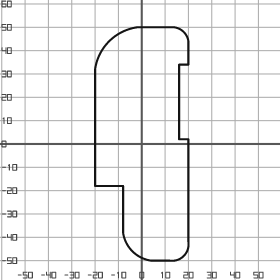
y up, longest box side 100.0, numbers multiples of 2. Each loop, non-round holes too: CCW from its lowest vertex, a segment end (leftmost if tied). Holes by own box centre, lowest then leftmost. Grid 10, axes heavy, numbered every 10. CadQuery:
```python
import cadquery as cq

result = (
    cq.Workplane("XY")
    .moveTo(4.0, -50.0)
    .lineTo(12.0, -50.0)
    .threePointArc((18.0, -48.0), (20.0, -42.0))
    .lineTo(20.0, 2.0)
    .lineTo(16.0, 2.0)
    .lineTo(16.0, 34.0)
    .lineTo(20.0, 34.0)
    .lineTo(20.0, 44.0)
    .threePointArc((18.0, 48.0), (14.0, 50.0))
    .lineTo(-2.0, 50.0)
    .threePointArc((-14.0, 44.0), (-20.0, 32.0))
    .lineTo(-20.0, -18.0)
    .lineTo(-8.0, -18.0)
    .lineTo(-8.0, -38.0)
    .threePointArc((-4.0, -46.0), (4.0, -50.0))
    .close()
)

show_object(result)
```